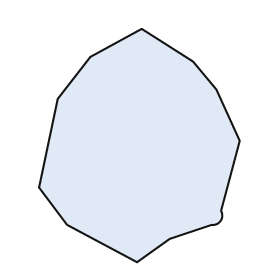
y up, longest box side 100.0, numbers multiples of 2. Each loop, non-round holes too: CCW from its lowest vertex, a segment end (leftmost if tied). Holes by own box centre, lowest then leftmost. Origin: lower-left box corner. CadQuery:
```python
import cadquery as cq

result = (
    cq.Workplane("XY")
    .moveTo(42.0, 0.0)
    .lineTo(56.0, 10.0)
    .lineTo(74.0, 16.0)
    .threePointArc((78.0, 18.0), (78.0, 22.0))
    .lineTo(86.0, 52.0)
    .lineTo(76.0, 74.0)
    .lineTo(66.0, 86.0)
    .lineTo(44.0, 100.0)
    .lineTo(22.0, 88.0)
    .lineTo(8.0, 70.0)
    .lineTo(0.0, 32.0)
    .lineTo(12.0, 16.0)
    .close()
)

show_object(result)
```